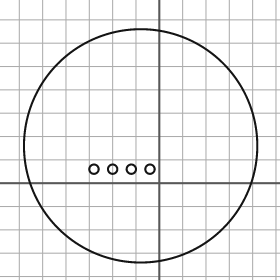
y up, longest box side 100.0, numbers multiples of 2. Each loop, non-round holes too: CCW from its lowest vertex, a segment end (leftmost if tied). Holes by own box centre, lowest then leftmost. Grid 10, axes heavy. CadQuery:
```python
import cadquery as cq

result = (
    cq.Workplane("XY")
    .moveTo(-8.0, 16.0)
    .circle(50.0)
    .moveTo(-28.0, 6.0)
    .circle(2.0)
    .moveTo(-20.0, 6.0)
    .circle(2.0)
    .moveTo(-12.0, 6.0)
    .circle(2.0)
    .moveTo(-4.0, 6.0)
    .circle(2.0)
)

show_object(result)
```